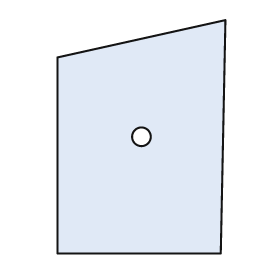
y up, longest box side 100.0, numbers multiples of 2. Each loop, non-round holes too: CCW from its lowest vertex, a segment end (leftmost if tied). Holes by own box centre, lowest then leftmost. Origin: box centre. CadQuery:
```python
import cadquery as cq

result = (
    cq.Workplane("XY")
    .moveTo(-36.0, -50.0)
    .lineTo(34.0, -50.0)
    .lineTo(36.0, 50.0)
    .lineTo(-36.0, 34.0)
    .close()
    .moveTo(0.0, 0.0)
    .circle(4.0)
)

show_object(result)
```